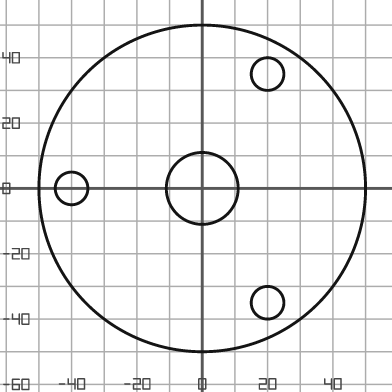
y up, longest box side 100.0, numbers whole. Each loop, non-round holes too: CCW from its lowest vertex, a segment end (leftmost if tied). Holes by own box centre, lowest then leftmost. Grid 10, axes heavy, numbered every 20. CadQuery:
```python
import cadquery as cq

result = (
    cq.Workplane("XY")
    .moveTo(0.0, 0.0)
    .circle(50.0)
    .moveTo(20.0, -35.0)
    .circle(5.0)
    .moveTo(-40.0, 0.0)
    .circle(5.0)
    .moveTo(0.0, 0.0)
    .circle(11.0)
    .moveTo(20.0, 35.0)
    .circle(5.0)
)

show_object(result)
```